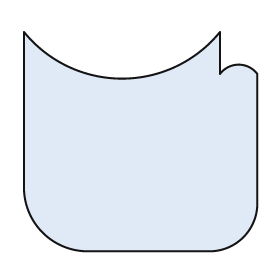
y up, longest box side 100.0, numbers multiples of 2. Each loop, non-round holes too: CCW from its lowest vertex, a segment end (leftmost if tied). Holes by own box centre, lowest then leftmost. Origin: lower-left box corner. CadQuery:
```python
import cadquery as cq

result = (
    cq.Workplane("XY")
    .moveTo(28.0, 0.0)
    .lineTo(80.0, 0.0)
    .threePointArc((94.0, 6.0), (100.0, 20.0))
    .lineTo(100.0, 76.0)
    .threePointArc((92.0, 80.0), (84.0, 76.0))
    .lineTo(84.0, 94.0)
    .threePointArc((42.0, 74.0), (0.0, 94.0))
    .lineTo(0.0, 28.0)
    .threePointArc((8.0, 8.0), (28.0, 0.0))
    .close()
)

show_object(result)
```